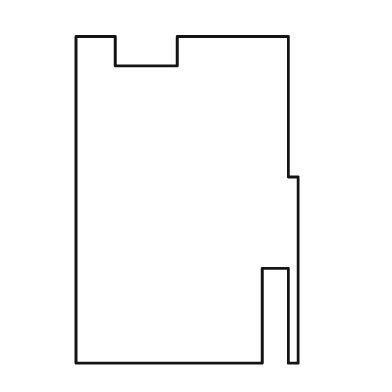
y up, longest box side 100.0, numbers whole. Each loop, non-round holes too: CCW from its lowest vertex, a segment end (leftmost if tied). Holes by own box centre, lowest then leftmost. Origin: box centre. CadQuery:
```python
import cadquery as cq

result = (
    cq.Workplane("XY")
    .moveTo(-34.0, -50.0)
    .lineTo(23.0, -50.0)
    .lineTo(23.0, -21.0)
    .lineTo(31.0, -21.0)
    .lineTo(31.0, -50.0)
    .lineTo(34.0, -50.0)
    .lineTo(34.0, 7.0)
    .lineTo(31.0, 7.0)
    .lineTo(31.0, 50.0)
    .lineTo(-3.0, 50.0)
    .lineTo(-3.0, 41.0)
    .lineTo(-22.0, 41.0)
    .lineTo(-22.0, 50.0)
    .lineTo(-34.0, 50.0)
    .close()
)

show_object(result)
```